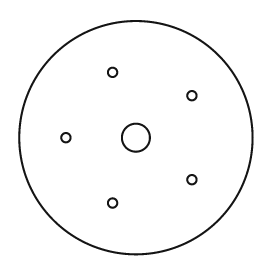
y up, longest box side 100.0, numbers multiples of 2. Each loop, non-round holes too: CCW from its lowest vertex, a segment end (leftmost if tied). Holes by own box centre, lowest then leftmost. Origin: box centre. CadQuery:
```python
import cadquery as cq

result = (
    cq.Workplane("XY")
    .moveTo(0.0, 0.0)
    .circle(50.0)
    .moveTo(-10.0, -28.0)
    .circle(2.0)
    .moveTo(24.0, -18.0)
    .circle(2.0)
    .moveTo(-30.0, 0.0)
    .circle(2.0)
    .moveTo(0.0, 0.0)
    .circle(6.0)
    .moveTo(24.0, 18.0)
    .circle(2.0)
    .moveTo(-10.0, 28.0)
    .circle(2.0)
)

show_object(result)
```